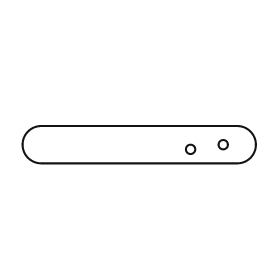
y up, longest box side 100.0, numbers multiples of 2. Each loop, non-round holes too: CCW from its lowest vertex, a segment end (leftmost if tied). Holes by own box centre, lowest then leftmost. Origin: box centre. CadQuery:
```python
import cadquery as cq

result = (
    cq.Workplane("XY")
    .moveTo(-42.0, -8.0)
    .lineTo(42.0, -8.0)
    .threePointArc((50.0, 0.0), (42.0, 8.0))
    .lineTo(-42.0, 8.0)
    .threePointArc((-50.0, 0.0), (-42.0, -8.0))
    .close()
    .moveTo(22.0, -2.0)
    .circle(2.0)
    .moveTo(36.0, 0.0)
    .circle(2.0)
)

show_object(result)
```